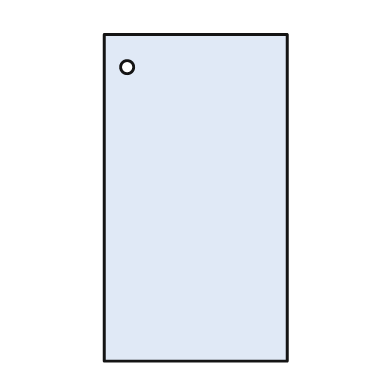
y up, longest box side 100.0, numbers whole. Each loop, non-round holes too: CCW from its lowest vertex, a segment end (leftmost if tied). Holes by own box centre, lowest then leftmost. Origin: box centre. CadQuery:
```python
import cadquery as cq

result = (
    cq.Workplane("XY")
    .moveTo(-28.0, -50.0)
    .lineTo(28.0, -50.0)
    .lineTo(28.0, 50.0)
    .lineTo(-28.0, 50.0)
    .close()
    .moveTo(-21.0, 40.0)
    .circle(2.0)
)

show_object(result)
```